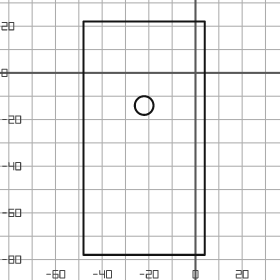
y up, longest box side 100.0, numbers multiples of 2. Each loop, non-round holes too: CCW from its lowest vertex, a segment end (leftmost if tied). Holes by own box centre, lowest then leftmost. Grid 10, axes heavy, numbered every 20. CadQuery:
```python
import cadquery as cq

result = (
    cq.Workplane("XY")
    .moveTo(-48.0, -78.0)
    .lineTo(4.0, -78.0)
    .lineTo(4.0, 22.0)
    .lineTo(-48.0, 22.0)
    .close()
    .moveTo(-22.0, -14.0)
    .circle(4.0)
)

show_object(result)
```